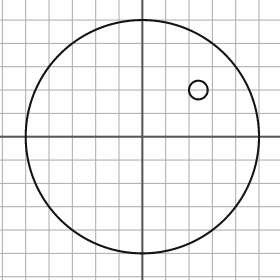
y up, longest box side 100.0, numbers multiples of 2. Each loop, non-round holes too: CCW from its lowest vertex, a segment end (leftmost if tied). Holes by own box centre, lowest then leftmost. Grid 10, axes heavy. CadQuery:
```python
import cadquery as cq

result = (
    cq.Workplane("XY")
    .moveTo(0.0, 0.0)
    .circle(50.0)
    .moveTo(24.0, 20.0)
    .circle(4.0)
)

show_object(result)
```